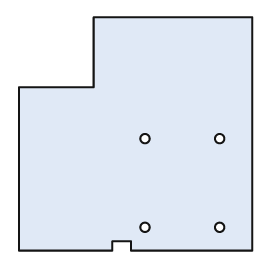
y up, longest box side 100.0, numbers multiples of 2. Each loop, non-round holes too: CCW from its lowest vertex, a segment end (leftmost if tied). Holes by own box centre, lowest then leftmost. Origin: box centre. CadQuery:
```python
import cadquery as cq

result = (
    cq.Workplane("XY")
    .moveTo(-50.0, -50.0)
    .lineTo(-10.0, -50.0)
    .lineTo(-10.0, -46.0)
    .lineTo(-2.0, -46.0)
    .lineTo(-2.0, -50.0)
    .lineTo(50.0, -50.0)
    .lineTo(50.0, 50.0)
    .lineTo(-18.0, 50.0)
    .lineTo(-18.0, 20.0)
    .lineTo(-50.0, 20.0)
    .close()
    .moveTo(4.0, -40.0)
    .circle(2.0)
    .moveTo(36.0, -40.0)
    .circle(2.0)
    .moveTo(4.0, -2.0)
    .circle(2.0)
    .moveTo(36.0, -2.0)
    .circle(2.0)
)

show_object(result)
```